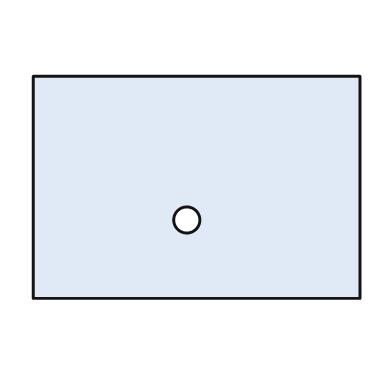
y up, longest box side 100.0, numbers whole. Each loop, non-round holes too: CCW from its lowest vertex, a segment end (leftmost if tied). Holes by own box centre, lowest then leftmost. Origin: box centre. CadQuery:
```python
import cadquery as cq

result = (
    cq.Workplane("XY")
    .moveTo(-50.0, -34.0)
    .lineTo(50.0, -34.0)
    .lineTo(50.0, 34.0)
    .lineTo(-50.0, 34.0)
    .close()
    .moveTo(-3.0, -10.0)
    .circle(4.0)
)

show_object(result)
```